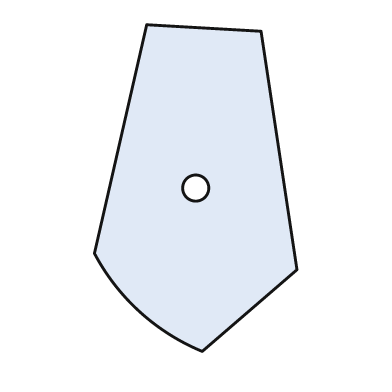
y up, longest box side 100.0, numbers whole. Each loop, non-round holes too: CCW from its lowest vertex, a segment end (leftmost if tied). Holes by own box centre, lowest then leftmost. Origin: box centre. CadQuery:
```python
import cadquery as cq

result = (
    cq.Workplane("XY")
    .moveTo(2.0, -50.0)
    .lineTo(31.0, -25.0)
    .lineTo(20.0, 48.0)
    .lineTo(-15.0, 50.0)
    .lineTo(-31.0, -20.0)
    .threePointArc((-17.0, -38.0), (2.0, -50.0))
    .close()
    .moveTo(0.0, 0.0)
    .circle(4.0)
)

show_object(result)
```